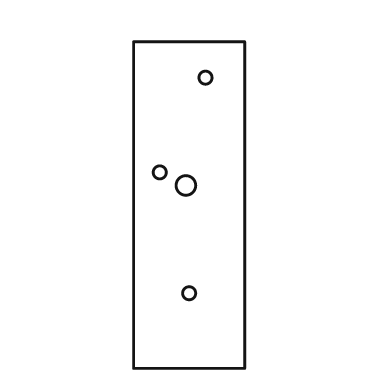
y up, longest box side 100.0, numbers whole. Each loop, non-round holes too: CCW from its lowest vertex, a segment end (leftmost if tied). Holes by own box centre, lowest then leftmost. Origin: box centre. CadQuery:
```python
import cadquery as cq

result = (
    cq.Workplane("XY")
    .moveTo(-17.0, -50.0)
    .lineTo(17.0, -50.0)
    .lineTo(17.0, 50.0)
    .lineTo(-17.0, 50.0)
    .close()
    .moveTo(0.0, -27.0)
    .circle(2.0)
    .moveTo(-1.0, 6.0)
    .circle(3.0)
    .moveTo(-9.0, 10.0)
    .circle(2.0)
    .moveTo(5.0, 39.0)
    .circle(2.0)
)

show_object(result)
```